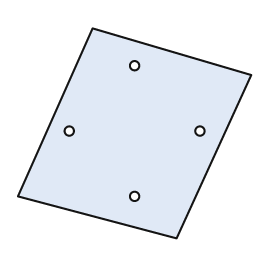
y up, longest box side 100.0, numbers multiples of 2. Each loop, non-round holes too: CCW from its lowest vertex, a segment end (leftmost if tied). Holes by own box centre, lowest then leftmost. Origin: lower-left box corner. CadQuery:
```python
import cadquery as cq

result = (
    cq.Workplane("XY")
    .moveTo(68.0, 0.0)
    .lineTo(100.0, 70.0)
    .lineTo(32.0, 90.0)
    .lineTo(0.0, 18.0)
    .close()
    .moveTo(50.0, 18.0)
    .circle(2.0)
    .moveTo(22.0, 46.0)
    .circle(2.0)
    .moveTo(78.0, 46.0)
    .circle(2.0)
    .moveTo(50.0, 74.0)
    .circle(2.0)
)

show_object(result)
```